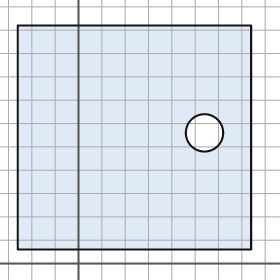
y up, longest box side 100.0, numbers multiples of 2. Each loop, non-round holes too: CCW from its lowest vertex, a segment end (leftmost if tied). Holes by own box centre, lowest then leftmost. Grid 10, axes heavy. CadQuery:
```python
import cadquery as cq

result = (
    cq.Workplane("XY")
    .moveTo(-26.0, 6.0)
    .lineTo(74.0, 6.0)
    .lineTo(74.0, 102.0)
    .lineTo(-26.0, 102.0)
    .close()
    .moveTo(54.0, 56.0)
    .circle(8.0)
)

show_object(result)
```